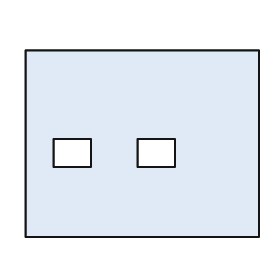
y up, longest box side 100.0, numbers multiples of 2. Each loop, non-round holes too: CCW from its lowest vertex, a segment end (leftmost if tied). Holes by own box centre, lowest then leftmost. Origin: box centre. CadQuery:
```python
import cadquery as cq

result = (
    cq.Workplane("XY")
    .moveTo(-50.0, -40.0)
    .lineTo(50.0, -40.0)
    .lineTo(50.0, 40.0)
    .lineTo(-50.0, 40.0)
    .close()
    .moveTo(-38.0, -10.0)
    .lineTo(-22.0, -10.0)
    .lineTo(-22.0, 2.0)
    .lineTo(-38.0, 2.0)
    .close()
    .moveTo(-2.0, -10.0)
    .lineTo(14.0, -10.0)
    .lineTo(14.0, 2.0)
    .lineTo(-2.0, 2.0)
    .close()
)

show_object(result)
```